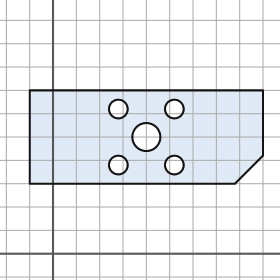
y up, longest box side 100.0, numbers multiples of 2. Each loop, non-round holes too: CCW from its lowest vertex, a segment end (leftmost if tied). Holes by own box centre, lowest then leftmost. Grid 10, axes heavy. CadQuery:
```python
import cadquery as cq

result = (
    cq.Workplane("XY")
    .moveTo(-10.0, 30.0)
    .lineTo(78.0, 30.0)
    .lineTo(90.0, 42.0)
    .lineTo(90.0, 70.0)
    .lineTo(-10.0, 70.0)
    .close()
    .moveTo(28.0, 38.0)
    .circle(4.0)
    .moveTo(52.0, 38.0)
    .circle(4.0)
    .moveTo(40.0, 50.0)
    .circle(6.0)
    .moveTo(28.0, 62.0)
    .circle(4.0)
    .moveTo(52.0, 62.0)
    .circle(4.0)
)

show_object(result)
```